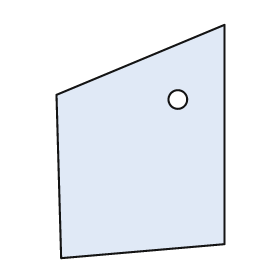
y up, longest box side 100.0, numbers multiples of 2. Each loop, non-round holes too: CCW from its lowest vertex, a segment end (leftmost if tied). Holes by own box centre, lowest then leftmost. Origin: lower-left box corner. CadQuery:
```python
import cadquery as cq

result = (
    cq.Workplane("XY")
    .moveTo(2.0, 0.0)
    .lineTo(72.0, 6.0)
    .lineTo(72.0, 100.0)
    .lineTo(0.0, 70.0)
    .close()
    .moveTo(52.0, 68.0)
    .circle(4.0)
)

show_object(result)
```